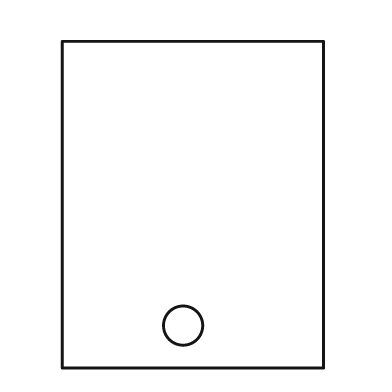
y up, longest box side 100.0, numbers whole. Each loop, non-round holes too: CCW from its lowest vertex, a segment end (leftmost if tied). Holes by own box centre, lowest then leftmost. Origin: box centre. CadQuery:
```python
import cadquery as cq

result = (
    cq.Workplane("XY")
    .moveTo(-40.0, -50.0)
    .lineTo(40.0, -50.0)
    .lineTo(40.0, 50.0)
    .lineTo(-40.0, 50.0)
    .close()
    .moveTo(-3.0, -37.0)
    .circle(6.0)
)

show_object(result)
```